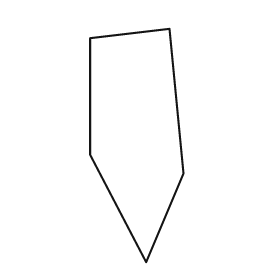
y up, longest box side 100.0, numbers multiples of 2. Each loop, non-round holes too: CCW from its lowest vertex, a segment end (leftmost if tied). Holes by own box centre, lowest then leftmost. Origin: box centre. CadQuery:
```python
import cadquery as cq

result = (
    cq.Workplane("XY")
    .moveTo(4.0, -50.0)
    .lineTo(20.0, -12.0)
    .lineTo(14.0, 50.0)
    .lineTo(-20.0, 46.0)
    .lineTo(-20.0, -4.0)
    .close()
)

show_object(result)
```